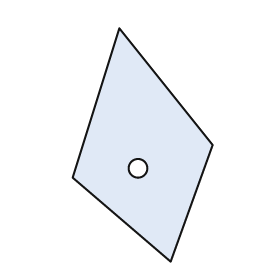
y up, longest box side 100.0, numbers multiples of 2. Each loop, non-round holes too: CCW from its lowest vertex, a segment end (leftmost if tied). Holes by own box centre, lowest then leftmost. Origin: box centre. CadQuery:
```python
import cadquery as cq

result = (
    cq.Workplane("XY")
    .moveTo(12.0, -50.0)
    .lineTo(30.0, 0.0)
    .lineTo(-10.0, 50.0)
    .lineTo(-30.0, -14.0)
    .close()
    .moveTo(-2.0, -10.0)
    .circle(4.0)
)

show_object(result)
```